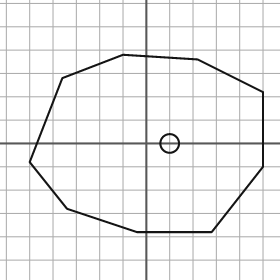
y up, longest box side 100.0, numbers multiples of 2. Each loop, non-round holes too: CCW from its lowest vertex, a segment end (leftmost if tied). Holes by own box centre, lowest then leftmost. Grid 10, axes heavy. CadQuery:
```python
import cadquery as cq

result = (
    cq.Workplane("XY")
    .moveTo(-4.0, -38.0)
    .lineTo(28.0, -38.0)
    .lineTo(50.0, -10.0)
    .lineTo(50.0, 22.0)
    .lineTo(22.0, 36.0)
    .lineTo(-10.0, 38.0)
    .lineTo(-36.0, 28.0)
    .lineTo(-50.0, -8.0)
    .lineTo(-34.0, -28.0)
    .close()
    .moveTo(10.0, 0.0)
    .circle(4.0)
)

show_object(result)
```